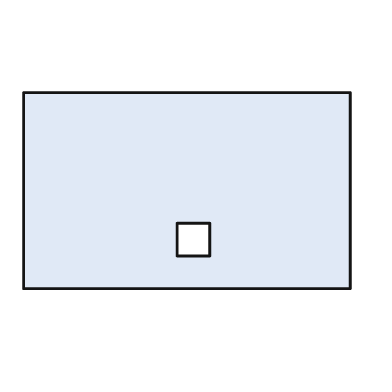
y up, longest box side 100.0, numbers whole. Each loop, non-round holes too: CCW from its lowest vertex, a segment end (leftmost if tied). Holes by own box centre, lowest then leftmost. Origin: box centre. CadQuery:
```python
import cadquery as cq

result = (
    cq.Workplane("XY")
    .moveTo(-50.0, -30.0)
    .lineTo(50.0, -30.0)
    .lineTo(50.0, 30.0)
    .lineTo(-50.0, 30.0)
    .close()
    .moveTo(-3.0, -20.0)
    .lineTo(7.0, -20.0)
    .lineTo(7.0, -10.0)
    .lineTo(-3.0, -10.0)
    .close()
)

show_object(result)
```